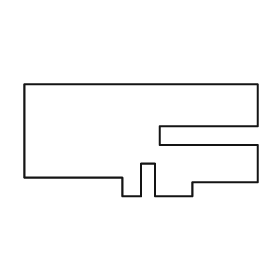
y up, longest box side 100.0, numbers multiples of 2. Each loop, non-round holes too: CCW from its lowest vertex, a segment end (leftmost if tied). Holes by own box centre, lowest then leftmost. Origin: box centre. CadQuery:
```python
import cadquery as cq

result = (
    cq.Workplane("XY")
    .moveTo(-8.0, -24.0)
    .lineTo(0.0, -24.0)
    .lineTo(0.0, -10.0)
    .lineTo(6.0, -10.0)
    .lineTo(6.0, -24.0)
    .lineTo(22.0, -24.0)
    .lineTo(22.0, -18.0)
    .lineTo(50.0, -18.0)
    .lineTo(50.0, -2.0)
    .lineTo(8.0, -2.0)
    .lineTo(8.0, 6.0)
    .lineTo(50.0, 6.0)
    .lineTo(50.0, 24.0)
    .lineTo(-50.0, 24.0)
    .lineTo(-50.0, -16.0)
    .lineTo(-8.0, -16.0)
    .close()
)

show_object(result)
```